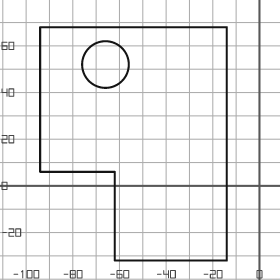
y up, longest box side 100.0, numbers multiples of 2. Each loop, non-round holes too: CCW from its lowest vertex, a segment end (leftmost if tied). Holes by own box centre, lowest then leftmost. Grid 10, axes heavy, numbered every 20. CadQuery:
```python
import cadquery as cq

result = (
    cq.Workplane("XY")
    .moveTo(-62.0, -32.0)
    .lineTo(-14.0, -32.0)
    .lineTo(-14.0, 68.0)
    .lineTo(-94.0, 68.0)
    .lineTo(-94.0, 6.0)
    .lineTo(-62.0, 6.0)
    .close()
    .moveTo(-66.0, 52.0)
    .circle(10.0)
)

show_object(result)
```